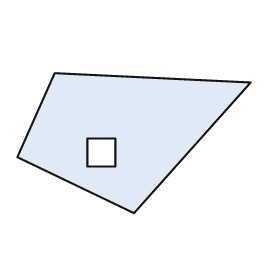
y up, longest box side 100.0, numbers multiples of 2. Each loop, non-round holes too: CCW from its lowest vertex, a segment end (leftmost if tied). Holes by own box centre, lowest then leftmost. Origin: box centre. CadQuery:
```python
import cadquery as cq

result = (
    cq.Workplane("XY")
    .moveTo(0.0, -30.0)
    .lineTo(50.0, 26.0)
    .lineTo(-34.0, 30.0)
    .lineTo(-50.0, -6.0)
    .close()
    .moveTo(-20.0, -10.0)
    .lineTo(-8.0, -10.0)
    .lineTo(-8.0, 2.0)
    .lineTo(-20.0, 2.0)
    .close()
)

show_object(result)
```